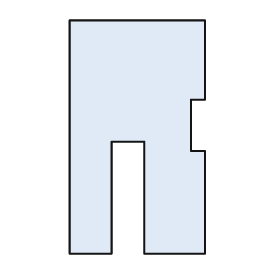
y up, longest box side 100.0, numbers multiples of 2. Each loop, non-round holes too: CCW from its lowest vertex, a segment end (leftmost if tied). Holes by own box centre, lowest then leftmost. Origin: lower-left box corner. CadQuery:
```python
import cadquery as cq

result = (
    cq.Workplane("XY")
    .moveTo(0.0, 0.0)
    .lineTo(18.0, 0.0)
    .lineTo(18.0, 48.0)
    .lineTo(32.0, 48.0)
    .lineTo(32.0, 0.0)
    .lineTo(58.0, 0.0)
    .lineTo(58.0, 44.0)
    .lineTo(52.0, 44.0)
    .lineTo(52.0, 66.0)
    .lineTo(58.0, 66.0)
    .lineTo(58.0, 100.0)
    .lineTo(0.0, 100.0)
    .close()
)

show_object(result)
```